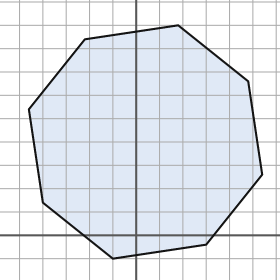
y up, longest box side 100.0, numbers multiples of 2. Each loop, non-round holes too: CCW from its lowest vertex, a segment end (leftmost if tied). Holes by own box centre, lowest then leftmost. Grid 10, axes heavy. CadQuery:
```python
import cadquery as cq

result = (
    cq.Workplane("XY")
    .moveTo(-10.0, -10.0)
    .lineTo(30.0, -4.0)
    .lineTo(54.0, 26.0)
    .lineTo(48.0, 66.0)
    .lineTo(18.0, 90.0)
    .lineTo(-22.0, 84.0)
    .lineTo(-46.0, 54.0)
    .lineTo(-40.0, 14.0)
    .close()
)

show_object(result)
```